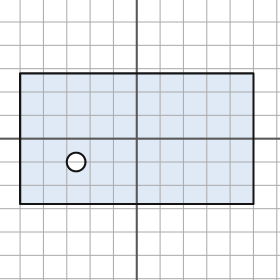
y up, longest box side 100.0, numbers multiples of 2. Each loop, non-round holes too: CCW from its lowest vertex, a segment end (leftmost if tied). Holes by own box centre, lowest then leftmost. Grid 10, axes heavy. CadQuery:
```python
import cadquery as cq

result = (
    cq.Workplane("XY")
    .moveTo(-50.0, -28.0)
    .lineTo(50.0, -28.0)
    .lineTo(50.0, 28.0)
    .lineTo(-50.0, 28.0)
    .close()
    .moveTo(-26.0, -10.0)
    .circle(4.0)
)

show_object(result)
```